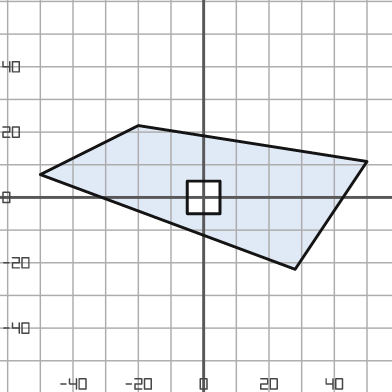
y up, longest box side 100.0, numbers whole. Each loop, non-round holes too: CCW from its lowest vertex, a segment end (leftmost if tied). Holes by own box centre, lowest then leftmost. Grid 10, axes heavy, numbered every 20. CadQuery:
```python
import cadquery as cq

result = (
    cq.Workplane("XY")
    .moveTo(28.0, -22.0)
    .lineTo(50.0, 11.0)
    .lineTo(-20.0, 22.0)
    .lineTo(-50.0, 7.0)
    .close()
    .moveTo(-5.0, -5.0)
    .lineTo(5.0, -5.0)
    .lineTo(5.0, 5.0)
    .lineTo(-5.0, 5.0)
    .close()
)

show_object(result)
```